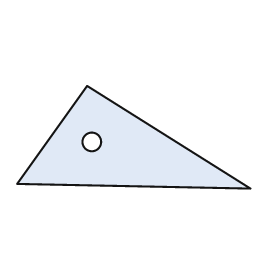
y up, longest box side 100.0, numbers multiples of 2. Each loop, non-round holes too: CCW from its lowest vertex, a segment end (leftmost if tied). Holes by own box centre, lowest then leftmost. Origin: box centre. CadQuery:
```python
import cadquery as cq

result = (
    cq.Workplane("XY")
    .moveTo(50.0, -22.0)
    .lineTo(-20.0, 22.0)
    .lineTo(-50.0, -20.0)
    .close()
    .moveTo(-18.0, -2.0)
    .circle(4.0)
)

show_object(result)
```